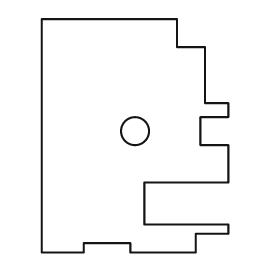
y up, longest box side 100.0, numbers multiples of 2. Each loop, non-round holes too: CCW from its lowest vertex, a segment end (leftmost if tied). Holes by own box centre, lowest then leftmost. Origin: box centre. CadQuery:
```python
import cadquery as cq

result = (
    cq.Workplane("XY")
    .moveTo(-40.0, -50.0)
    .lineTo(-22.0, -50.0)
    .lineTo(-22.0, -46.0)
    .lineTo(-2.0, -46.0)
    .lineTo(-2.0, -50.0)
    .lineTo(26.0, -50.0)
    .lineTo(26.0, -42.0)
    .lineTo(40.0, -42.0)
    .lineTo(40.0, -38.0)
    .lineTo(4.0, -38.0)
    .lineTo(4.0, -20.0)
    .lineTo(40.0, -20.0)
    .lineTo(40.0, -4.0)
    .lineTo(28.0, -4.0)
    .lineTo(28.0, 8.0)
    .lineTo(40.0, 8.0)
    .lineTo(40.0, 14.0)
    .lineTo(30.0, 14.0)
    .lineTo(30.0, 38.0)
    .lineTo(18.0, 38.0)
    .lineTo(18.0, 50.0)
    .lineTo(-40.0, 50.0)
    .close()
    .moveTo(0.0, 2.0)
    .circle(6.0)
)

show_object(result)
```